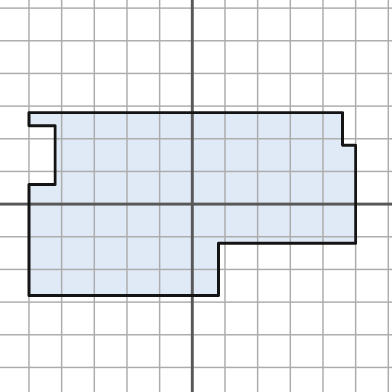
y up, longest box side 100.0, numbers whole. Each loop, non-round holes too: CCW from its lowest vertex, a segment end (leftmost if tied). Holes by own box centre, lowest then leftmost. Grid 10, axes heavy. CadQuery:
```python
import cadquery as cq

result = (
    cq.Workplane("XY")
    .moveTo(-50.0, -28.0)
    .lineTo(8.0, -28.0)
    .lineTo(8.0, -12.0)
    .lineTo(50.0, -12.0)
    .lineTo(50.0, 18.0)
    .lineTo(46.0, 18.0)
    .lineTo(46.0, 28.0)
    .lineTo(-50.0, 28.0)
    .lineTo(-50.0, 24.0)
    .lineTo(-42.0, 24.0)
    .lineTo(-42.0, 6.0)
    .lineTo(-50.0, 6.0)
    .close()
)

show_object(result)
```